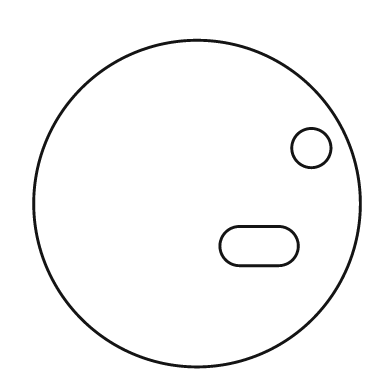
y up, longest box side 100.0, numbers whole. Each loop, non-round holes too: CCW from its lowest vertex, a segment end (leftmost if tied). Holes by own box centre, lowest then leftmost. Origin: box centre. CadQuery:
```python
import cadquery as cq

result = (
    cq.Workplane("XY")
    .moveTo(0.0, 0.0)
    .circle(50.0)
    .moveTo(13.0, -19.0)
    .lineTo(25.0, -19.0)
    .threePointArc((31.0, -13.0), (25.0, -7.0))
    .lineTo(13.0, -7.0)
    .threePointArc((7.0, -13.0), (13.0, -19.0))
    .close()
    .moveTo(35.0, 17.0)
    .circle(6.0)
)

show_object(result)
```